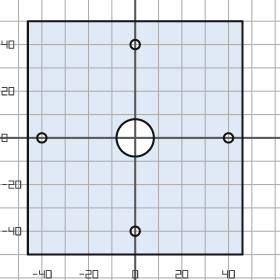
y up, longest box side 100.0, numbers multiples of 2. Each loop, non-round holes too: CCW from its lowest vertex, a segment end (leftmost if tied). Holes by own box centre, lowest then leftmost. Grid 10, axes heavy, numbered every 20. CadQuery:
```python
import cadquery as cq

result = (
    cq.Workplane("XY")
    .moveTo(-46.0, -50.0)
    .lineTo(46.0, -50.0)
    .lineTo(46.0, 50.0)
    .lineTo(-46.0, 50.0)
    .close()
    .moveTo(0.0, -40.0)
    .circle(2.0)
    .moveTo(-40.0, 0.0)
    .circle(2.0)
    .moveTo(0.0, 0.0)
    .circle(8.0)
    .moveTo(40.0, 0.0)
    .circle(2.0)
    .moveTo(0.0, 40.0)
    .circle(2.0)
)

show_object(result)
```